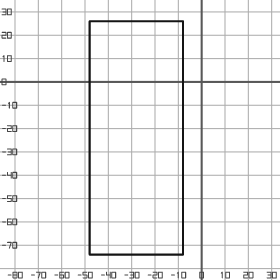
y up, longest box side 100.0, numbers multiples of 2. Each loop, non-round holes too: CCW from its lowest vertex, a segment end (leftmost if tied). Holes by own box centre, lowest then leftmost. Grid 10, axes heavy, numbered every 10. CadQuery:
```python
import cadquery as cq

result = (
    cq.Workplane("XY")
    .moveTo(-48.0, -74.0)
    .lineTo(-8.0, -74.0)
    .lineTo(-8.0, 26.0)
    .lineTo(-48.0, 26.0)
    .close()
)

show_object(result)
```